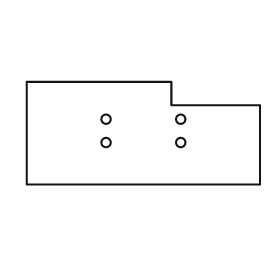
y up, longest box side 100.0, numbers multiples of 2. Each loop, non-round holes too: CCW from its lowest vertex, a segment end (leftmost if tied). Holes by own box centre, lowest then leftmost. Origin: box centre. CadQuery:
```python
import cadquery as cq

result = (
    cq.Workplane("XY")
    .moveTo(-50.0, -22.0)
    .lineTo(50.0, -22.0)
    .lineTo(50.0, 12.0)
    .lineTo(12.0, 12.0)
    .lineTo(12.0, 22.0)
    .lineTo(-50.0, 22.0)
    .close()
    .moveTo(-16.0, -4.0)
    .circle(2.0)
    .moveTo(16.0, -4.0)
    .circle(2.0)
    .moveTo(-16.0, 6.0)
    .circle(2.0)
    .moveTo(16.0, 6.0)
    .circle(2.0)
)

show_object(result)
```